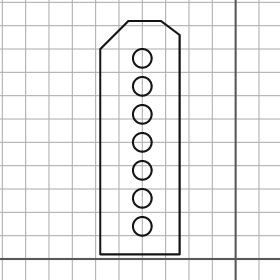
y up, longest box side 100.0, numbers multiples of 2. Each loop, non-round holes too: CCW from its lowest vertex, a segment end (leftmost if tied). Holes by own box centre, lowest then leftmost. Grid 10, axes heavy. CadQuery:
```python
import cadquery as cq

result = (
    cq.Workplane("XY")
    .moveTo(-58.0, 2.0)
    .lineTo(-24.0, 2.0)
    .lineTo(-24.0, 96.0)
    .lineTo(-32.0, 102.0)
    .lineTo(-46.0, 102.0)
    .lineTo(-58.0, 90.0)
    .close()
    .moveTo(-40.0, 14.0)
    .circle(4.0)
    .moveTo(-40.0, 26.0)
    .circle(4.0)
    .moveTo(-40.0, 38.0)
    .circle(4.0)
    .moveTo(-40.0, 50.0)
    .circle(4.0)
    .moveTo(-40.0, 62.0)
    .circle(4.0)
    .moveTo(-40.0, 74.0)
    .circle(4.0)
    .moveTo(-40.0, 86.0)
    .circle(4.0)
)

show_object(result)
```